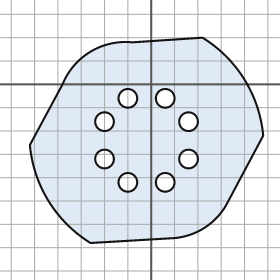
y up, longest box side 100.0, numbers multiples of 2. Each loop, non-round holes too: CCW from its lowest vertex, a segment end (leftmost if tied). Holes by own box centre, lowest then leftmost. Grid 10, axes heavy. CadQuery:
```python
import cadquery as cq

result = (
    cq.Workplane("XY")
    .moveTo(-26.0, -68.0)
    .lineTo(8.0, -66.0)
    .threePointArc((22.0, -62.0), (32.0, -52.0))
    .lineTo(48.0, -22.0)
    .threePointArc((40.0, 2.0), (22.0, 20.0))
    .lineTo(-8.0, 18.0)
    .threePointArc((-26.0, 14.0), (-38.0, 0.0))
    .lineTo(-52.0, -26.0)
    .threePointArc((-44.0, -50.0), (-26.0, -68.0))
    .close()
    .moveTo(-10.0, -42.0)
    .circle(4.0)
    .moveTo(6.0, -42.0)
    .circle(4.0)
    .moveTo(-20.0, -32.0)
    .circle(4.0)
    .moveTo(16.0, -32.0)
    .circle(4.0)
    .moveTo(-20.0, -16.0)
    .circle(4.0)
    .moveTo(16.0, -16.0)
    .circle(4.0)
    .moveTo(-10.0, -6.0)
    .circle(4.0)
    .moveTo(6.0, -6.0)
    .circle(4.0)
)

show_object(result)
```